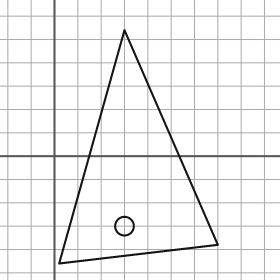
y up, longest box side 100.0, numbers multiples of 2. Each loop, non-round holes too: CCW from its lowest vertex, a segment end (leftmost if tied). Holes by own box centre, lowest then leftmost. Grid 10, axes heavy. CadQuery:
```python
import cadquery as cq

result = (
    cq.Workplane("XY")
    .moveTo(2.0, -46.0)
    .lineTo(70.0, -38.0)
    .lineTo(30.0, 54.0)
    .close()
    .moveTo(30.0, -30.0)
    .circle(4.0)
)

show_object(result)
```